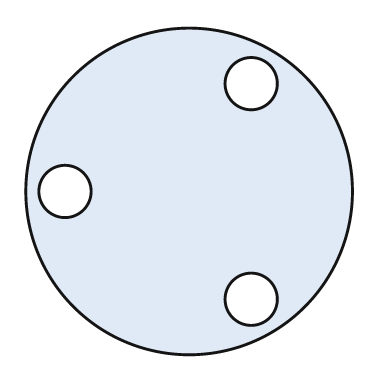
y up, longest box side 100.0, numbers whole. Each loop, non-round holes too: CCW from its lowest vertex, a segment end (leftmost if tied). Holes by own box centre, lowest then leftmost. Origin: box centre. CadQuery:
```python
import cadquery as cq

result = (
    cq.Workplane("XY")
    .moveTo(0.0, 0.0)
    .circle(50.0)
    .moveTo(19.0, -33.0)
    .circle(8.0)
    .moveTo(-38.0, 0.0)
    .circle(8.0)
    .moveTo(19.0, 33.0)
    .circle(8.0)
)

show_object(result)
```